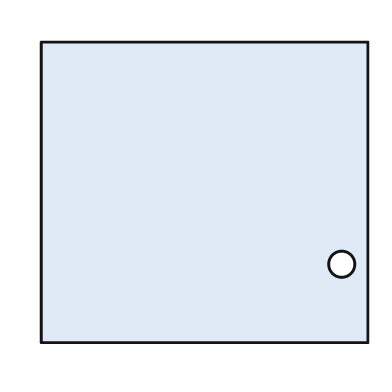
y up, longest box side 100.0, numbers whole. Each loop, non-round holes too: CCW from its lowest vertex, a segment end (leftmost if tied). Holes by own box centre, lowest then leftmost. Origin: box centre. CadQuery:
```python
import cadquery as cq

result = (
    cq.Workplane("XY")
    .moveTo(-50.0, -46.0)
    .lineTo(50.0, -46.0)
    .lineTo(50.0, 46.0)
    .lineTo(-50.0, 46.0)
    .close()
    .moveTo(42.0, -22.0)
    .circle(4.0)
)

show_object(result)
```